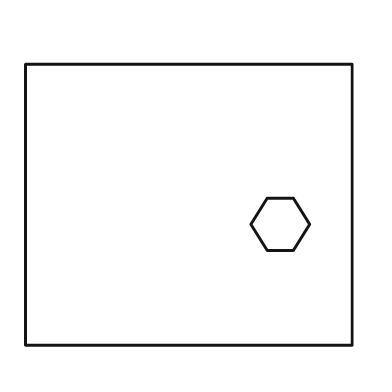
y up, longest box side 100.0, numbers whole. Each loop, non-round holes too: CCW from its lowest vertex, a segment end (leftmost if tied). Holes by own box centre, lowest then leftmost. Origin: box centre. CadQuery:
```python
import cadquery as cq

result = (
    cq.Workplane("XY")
    .moveTo(-50.0, -43.0)
    .lineTo(50.0, -43.0)
    .lineTo(50.0, 43.0)
    .lineTo(-50.0, 43.0)
    .close()
    .moveTo(24.0, -14.0)
    .lineTo(32.0, -14.0)
    .lineTo(37.0, -6.0)
    .lineTo(32.0, 2.0)
    .lineTo(24.0, 2.0)
    .lineTo(19.0, -6.0)
    .close()
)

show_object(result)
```